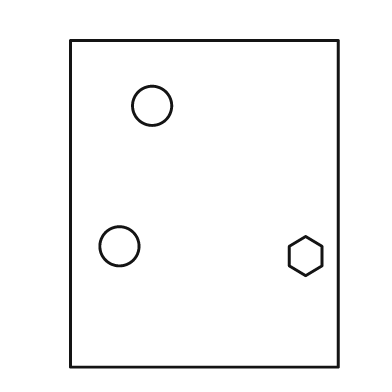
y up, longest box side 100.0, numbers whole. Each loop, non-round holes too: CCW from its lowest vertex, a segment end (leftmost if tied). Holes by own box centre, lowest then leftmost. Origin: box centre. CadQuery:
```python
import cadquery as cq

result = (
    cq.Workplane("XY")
    .moveTo(-41.0, -50.0)
    .lineTo(41.0, -50.0)
    .lineTo(41.0, 50.0)
    .lineTo(-41.0, 50.0)
    .close()
    .moveTo(31.0, -22.0)
    .lineTo(36.0, -19.0)
    .lineTo(36.0, -13.0)
    .lineTo(31.0, -10.0)
    .lineTo(26.0, -13.0)
    .lineTo(26.0, -19.0)
    .close()
    .moveTo(-26.0, -13.0)
    .circle(6.0)
    .moveTo(-16.0, 30.0)
    .circle(6.0)
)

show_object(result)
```